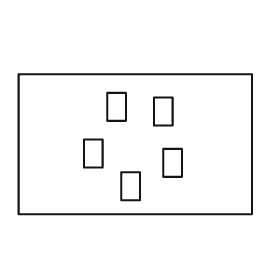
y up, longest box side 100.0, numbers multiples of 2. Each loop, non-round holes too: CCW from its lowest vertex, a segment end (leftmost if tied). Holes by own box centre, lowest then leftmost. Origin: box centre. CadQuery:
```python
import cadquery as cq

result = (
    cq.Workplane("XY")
    .moveTo(-50.0, -30.0)
    .lineTo(50.0, -30.0)
    .lineTo(50.0, 30.0)
    .lineTo(-50.0, 30.0)
    .close()
    .moveTo(-6.0, -24.0)
    .lineTo(2.0, -24.0)
    .lineTo(2.0, -12.0)
    .lineTo(-6.0, -12.0)
    .close()
    .moveTo(12.0, -14.0)
    .lineTo(20.0, -14.0)
    .lineTo(20.0, -2.0)
    .lineTo(12.0, -2.0)
    .close()
    .moveTo(-22.0, -10.0)
    .lineTo(-14.0, -10.0)
    .lineTo(-14.0, 2.0)
    .lineTo(-22.0, 2.0)
    .close()
    .moveTo(8.0, 8.0)
    .lineTo(16.0, 8.0)
    .lineTo(16.0, 20.0)
    .lineTo(8.0, 20.0)
    .close()
    .moveTo(-12.0, 10.0)
    .lineTo(-4.0, 10.0)
    .lineTo(-4.0, 22.0)
    .lineTo(-12.0, 22.0)
    .close()
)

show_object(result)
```